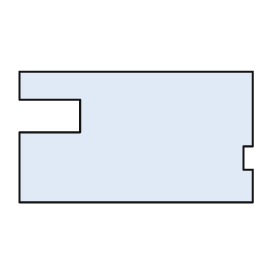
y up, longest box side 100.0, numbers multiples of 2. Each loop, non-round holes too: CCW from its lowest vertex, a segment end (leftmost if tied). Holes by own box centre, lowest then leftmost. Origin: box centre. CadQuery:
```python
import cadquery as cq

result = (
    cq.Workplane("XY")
    .moveTo(-50.0, -28.0)
    .lineTo(50.0, -28.0)
    .lineTo(50.0, -14.0)
    .lineTo(46.0, -14.0)
    .lineTo(46.0, -4.0)
    .lineTo(50.0, -4.0)
    .lineTo(50.0, 28.0)
    .lineTo(-50.0, 28.0)
    .lineTo(-50.0, 16.0)
    .lineTo(-24.0, 16.0)
    .lineTo(-24.0, 2.0)
    .lineTo(-50.0, 2.0)
    .close()
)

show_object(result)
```